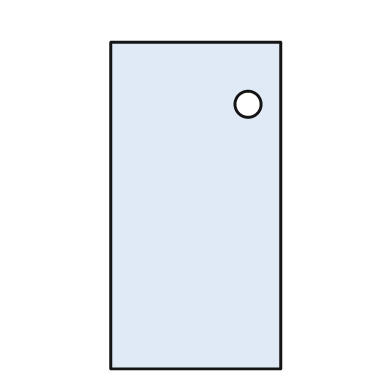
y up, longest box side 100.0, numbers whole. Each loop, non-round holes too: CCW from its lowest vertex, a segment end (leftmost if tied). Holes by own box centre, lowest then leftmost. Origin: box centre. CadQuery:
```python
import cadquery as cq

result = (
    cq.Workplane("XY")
    .moveTo(-26.0, -50.0)
    .lineTo(26.0, -50.0)
    .lineTo(26.0, 50.0)
    .lineTo(-26.0, 50.0)
    .close()
    .moveTo(16.0, 31.0)
    .circle(4.0)
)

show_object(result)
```